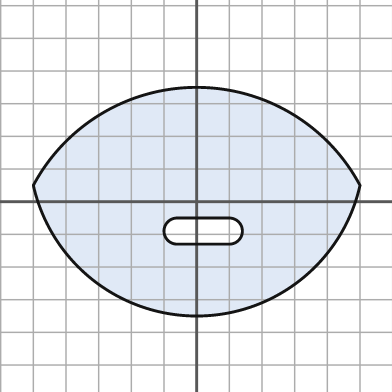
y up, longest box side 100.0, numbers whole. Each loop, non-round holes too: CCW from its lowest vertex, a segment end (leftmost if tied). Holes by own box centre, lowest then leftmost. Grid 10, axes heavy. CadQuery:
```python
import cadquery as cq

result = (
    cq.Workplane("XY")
    .moveTo(-50.0, 5.0)
    .threePointArc((0.0, -35.0), (50.0, 5.0))
    .threePointArc((0.0, 35.0), (-50.0, 5.0))
    .close()
    .moveTo(-6.0, -13.0)
    .lineTo(10.0, -13.0)
    .threePointArc((14.0, -9.0), (10.0, -5.0))
    .lineTo(-6.0, -5.0)
    .threePointArc((-10.0, -9.0), (-6.0, -13.0))
    .close()
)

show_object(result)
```